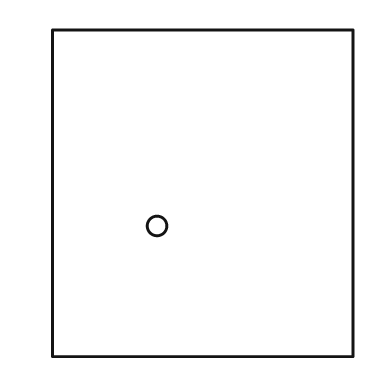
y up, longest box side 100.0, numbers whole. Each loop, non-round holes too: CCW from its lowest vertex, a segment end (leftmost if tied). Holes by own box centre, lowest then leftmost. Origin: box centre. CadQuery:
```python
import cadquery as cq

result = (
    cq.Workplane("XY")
    .moveTo(-46.0, -50.0)
    .lineTo(46.0, -50.0)
    .lineTo(46.0, 50.0)
    .lineTo(-46.0, 50.0)
    .close()
    .moveTo(-14.0, -10.0)
    .circle(3.0)
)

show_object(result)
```